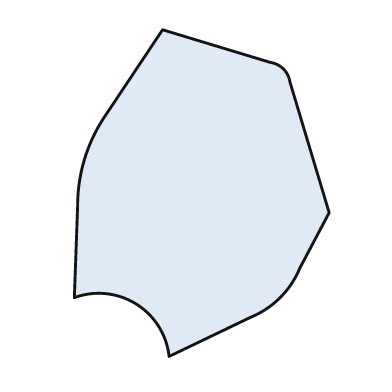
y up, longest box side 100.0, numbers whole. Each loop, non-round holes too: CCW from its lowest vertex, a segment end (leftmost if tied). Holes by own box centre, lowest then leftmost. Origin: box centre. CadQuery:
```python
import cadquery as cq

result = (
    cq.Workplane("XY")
    .moveTo(-10.0, -50.0)
    .lineTo(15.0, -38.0)
    .threePointArc((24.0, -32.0), (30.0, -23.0))
    .lineTo(39.0, -6.0)
    .lineTo(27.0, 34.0)
    .threePointArc((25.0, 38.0), (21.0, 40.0))
    .lineTo(-12.0, 50.0)
    .lineTo(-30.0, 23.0)
    .threePointArc((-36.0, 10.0), (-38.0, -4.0))
    .lineTo(-39.0, -32.0)
    .threePointArc((-20.0, -34.0), (-10.0, -50.0))
    .close()
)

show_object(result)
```